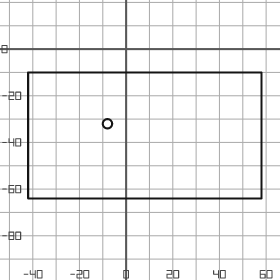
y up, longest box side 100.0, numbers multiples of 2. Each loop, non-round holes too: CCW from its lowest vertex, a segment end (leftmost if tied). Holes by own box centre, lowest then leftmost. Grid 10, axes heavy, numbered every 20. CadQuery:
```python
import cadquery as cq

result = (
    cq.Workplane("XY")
    .moveTo(-42.0, -64.0)
    .lineTo(58.0, -64.0)
    .lineTo(58.0, -10.0)
    .lineTo(-42.0, -10.0)
    .close()
    .moveTo(-8.0, -32.0)
    .circle(2.0)
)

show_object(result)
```